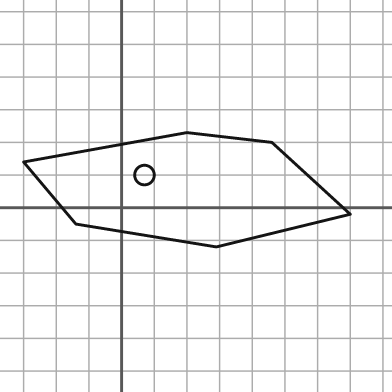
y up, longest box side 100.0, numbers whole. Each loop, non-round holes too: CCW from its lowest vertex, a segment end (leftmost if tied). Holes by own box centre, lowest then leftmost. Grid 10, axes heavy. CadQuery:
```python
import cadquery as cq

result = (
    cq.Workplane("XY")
    .moveTo(29.0, -12.0)
    .lineTo(70.0, -2.0)
    .lineTo(46.0, 20.0)
    .lineTo(20.0, 23.0)
    .lineTo(-30.0, 14.0)
    .lineTo(-14.0, -5.0)
    .close()
    .moveTo(7.0, 10.0)
    .circle(3.0)
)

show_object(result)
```